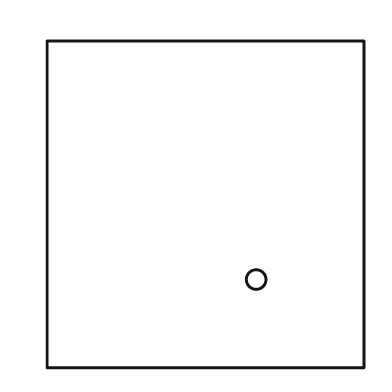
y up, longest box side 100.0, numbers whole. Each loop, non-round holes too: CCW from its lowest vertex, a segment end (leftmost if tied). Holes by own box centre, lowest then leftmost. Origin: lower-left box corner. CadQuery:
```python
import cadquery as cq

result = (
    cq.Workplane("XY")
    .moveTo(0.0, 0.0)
    .lineTo(97.0, 0.0)
    .lineTo(97.0, 100.0)
    .lineTo(0.0, 100.0)
    .close()
    .moveTo(64.0, 27.0)
    .circle(3.0)
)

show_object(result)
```